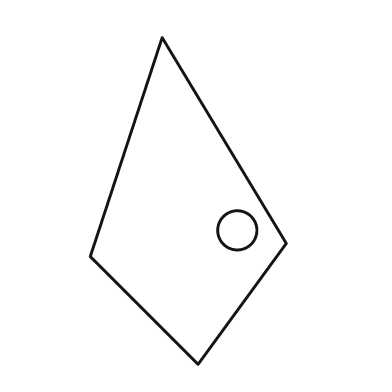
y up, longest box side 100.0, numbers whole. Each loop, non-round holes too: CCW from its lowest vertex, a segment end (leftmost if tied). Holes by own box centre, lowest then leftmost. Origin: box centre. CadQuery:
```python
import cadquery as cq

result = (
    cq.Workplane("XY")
    .moveTo(3.0, -50.0)
    .lineTo(30.0, -13.0)
    .lineTo(-8.0, 50.0)
    .lineTo(-30.0, -17.0)
    .close()
    .moveTo(15.0, -9.0)
    .circle(6.0)
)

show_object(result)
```